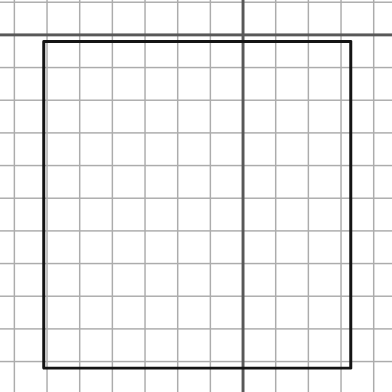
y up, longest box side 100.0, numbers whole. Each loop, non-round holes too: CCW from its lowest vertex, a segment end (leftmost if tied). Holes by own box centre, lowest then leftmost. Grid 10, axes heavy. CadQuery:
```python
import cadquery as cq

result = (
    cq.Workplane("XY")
    .moveTo(-61.0, -102.0)
    .lineTo(33.0, -102.0)
    .lineTo(33.0, -2.0)
    .lineTo(-61.0, -2.0)
    .close()
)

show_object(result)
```